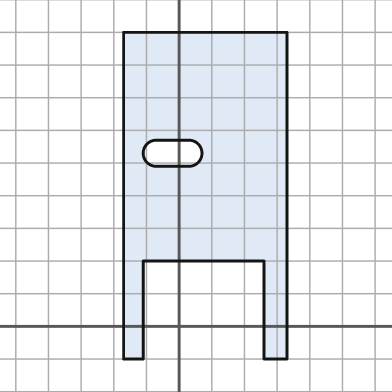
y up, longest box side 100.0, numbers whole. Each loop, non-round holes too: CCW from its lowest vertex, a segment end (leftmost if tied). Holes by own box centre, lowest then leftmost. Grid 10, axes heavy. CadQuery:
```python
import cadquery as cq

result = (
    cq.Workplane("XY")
    .moveTo(-17.0, -10.0)
    .lineTo(-11.0, -10.0)
    .lineTo(-11.0, 20.0)
    .lineTo(26.0, 20.0)
    .lineTo(26.0, -10.0)
    .lineTo(33.0, -10.0)
    .lineTo(33.0, 90.0)
    .lineTo(-17.0, 90.0)
    .close()
    .moveTo(-7.0, 49.0)
    .lineTo(3.0, 49.0)
    .threePointArc((7.0, 53.0), (3.0, 57.0))
    .lineTo(-7.0, 57.0)
    .threePointArc((-11.0, 53.0), (-7.0, 49.0))
    .close()
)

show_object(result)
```